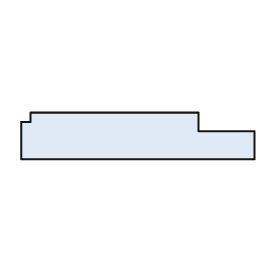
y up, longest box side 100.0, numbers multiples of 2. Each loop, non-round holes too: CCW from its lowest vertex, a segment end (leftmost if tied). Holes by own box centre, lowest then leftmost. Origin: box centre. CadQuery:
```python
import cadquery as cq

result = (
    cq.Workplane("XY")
    .moveTo(-50.0, -10.0)
    .lineTo(50.0, -10.0)
    .lineTo(50.0, 2.0)
    .lineTo(26.0, 2.0)
    .lineTo(26.0, 10.0)
    .lineTo(-46.0, 10.0)
    .lineTo(-46.0, 6.0)
    .lineTo(-50.0, 6.0)
    .close()
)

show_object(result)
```